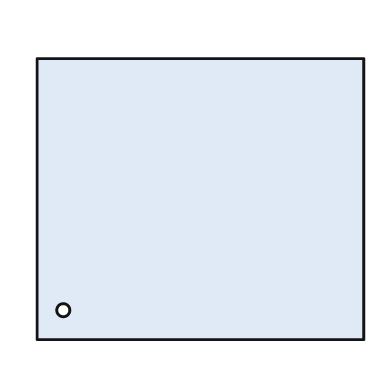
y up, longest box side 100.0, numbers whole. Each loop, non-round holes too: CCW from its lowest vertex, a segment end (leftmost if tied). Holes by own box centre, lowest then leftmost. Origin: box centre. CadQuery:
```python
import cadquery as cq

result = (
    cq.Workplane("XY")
    .moveTo(-50.0, -43.0)
    .lineTo(50.0, -43.0)
    .lineTo(50.0, 43.0)
    .lineTo(-50.0, 43.0)
    .close()
    .moveTo(-42.0, -34.0)
    .circle(2.0)
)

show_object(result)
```